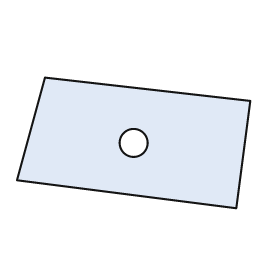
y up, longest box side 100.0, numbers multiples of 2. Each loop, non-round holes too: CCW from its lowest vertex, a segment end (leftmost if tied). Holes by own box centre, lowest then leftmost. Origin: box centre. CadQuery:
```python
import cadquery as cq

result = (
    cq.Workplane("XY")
    .moveTo(44.0, -28.0)
    .lineTo(50.0, 18.0)
    .lineTo(-38.0, 28.0)
    .lineTo(-50.0, -16.0)
    .close()
    .moveTo(0.0, 0.0)
    .circle(6.0)
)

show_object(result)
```